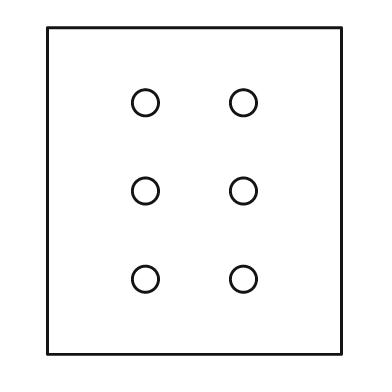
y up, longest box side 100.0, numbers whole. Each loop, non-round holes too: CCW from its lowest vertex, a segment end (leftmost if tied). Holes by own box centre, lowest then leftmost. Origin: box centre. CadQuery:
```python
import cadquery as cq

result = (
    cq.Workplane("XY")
    .moveTo(-45.0, -50.0)
    .lineTo(45.0, -50.0)
    .lineTo(45.0, 50.0)
    .lineTo(-45.0, 50.0)
    .close()
    .moveTo(-15.0, -27.0)
    .circle(4.0)
    .moveTo(15.0, -27.0)
    .circle(4.0)
    .moveTo(-15.0, 0.0)
    .circle(4.0)
    .moveTo(15.0, 0.0)
    .circle(4.0)
    .moveTo(-15.0, 27.0)
    .circle(4.0)
    .moveTo(15.0, 27.0)
    .circle(4.0)
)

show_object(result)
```